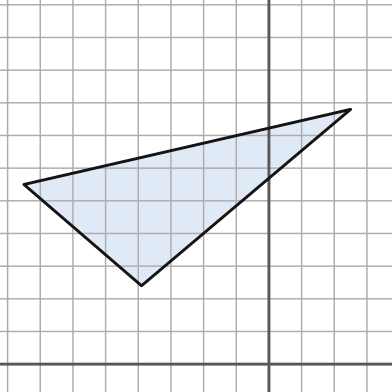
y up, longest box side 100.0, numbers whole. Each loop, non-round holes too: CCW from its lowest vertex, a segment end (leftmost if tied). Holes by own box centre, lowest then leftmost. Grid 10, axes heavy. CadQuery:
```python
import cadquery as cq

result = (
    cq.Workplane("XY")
    .moveTo(-39.0, 24.0)
    .lineTo(25.0, 78.0)
    .lineTo(-75.0, 55.0)
    .close()
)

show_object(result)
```